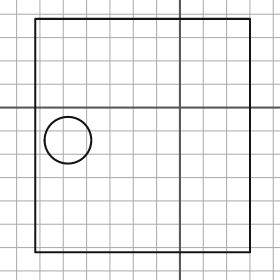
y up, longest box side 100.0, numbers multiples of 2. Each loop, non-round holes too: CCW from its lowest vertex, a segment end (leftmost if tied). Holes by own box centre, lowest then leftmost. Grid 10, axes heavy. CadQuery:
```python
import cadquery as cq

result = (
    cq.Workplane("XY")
    .moveTo(-62.0, -62.0)
    .lineTo(30.0, -62.0)
    .lineTo(30.0, 38.0)
    .lineTo(-62.0, 38.0)
    .close()
    .moveTo(-48.0, -14.0)
    .circle(10.0)
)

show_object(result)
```